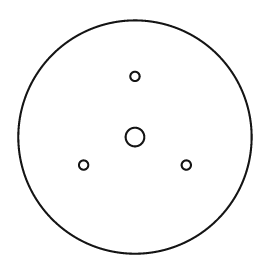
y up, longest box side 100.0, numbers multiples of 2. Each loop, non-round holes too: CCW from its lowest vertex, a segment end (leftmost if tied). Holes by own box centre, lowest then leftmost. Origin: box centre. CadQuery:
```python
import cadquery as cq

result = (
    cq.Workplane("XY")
    .moveTo(0.0, 0.0)
    .circle(50.0)
    .moveTo(-22.0, -12.0)
    .circle(2.0)
    .moveTo(22.0, -12.0)
    .circle(2.0)
    .moveTo(0.0, 0.0)
    .circle(4.0)
    .moveTo(0.0, 26.0)
    .circle(2.0)
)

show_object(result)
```